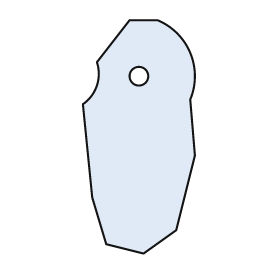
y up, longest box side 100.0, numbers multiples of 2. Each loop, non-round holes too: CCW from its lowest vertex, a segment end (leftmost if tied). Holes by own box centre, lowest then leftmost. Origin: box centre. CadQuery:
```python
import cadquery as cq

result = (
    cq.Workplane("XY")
    .moveTo(2.0, -50.0)
    .lineTo(16.0, -40.0)
    .lineTo(24.0, -8.0)
    .lineTo(22.0, 16.0)
    .threePointArc((22.0, 36.0), (8.0, 50.0))
    .lineTo(-4.0, 50.0)
    .lineTo(-18.0, 32.0)
    .threePointArc((-18.0, 22.0), (-24.0, 14.0))
    .lineTo(-20.0, -26.0)
    .lineTo(-14.0, -46.0)
    .close()
    .moveTo(0.0, 26.0)
    .circle(4.0)
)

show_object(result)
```